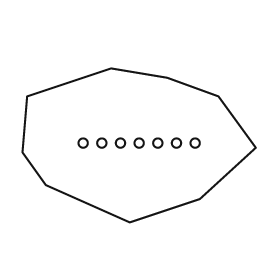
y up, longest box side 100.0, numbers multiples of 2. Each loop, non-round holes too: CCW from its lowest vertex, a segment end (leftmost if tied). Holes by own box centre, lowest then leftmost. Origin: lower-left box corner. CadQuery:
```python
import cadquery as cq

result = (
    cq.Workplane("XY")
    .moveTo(46.0, 0.0)
    .lineTo(76.0, 10.0)
    .lineTo(100.0, 32.0)
    .lineTo(84.0, 54.0)
    .lineTo(62.0, 62.0)
    .lineTo(38.0, 66.0)
    .lineTo(2.0, 54.0)
    .lineTo(0.0, 30.0)
    .lineTo(10.0, 16.0)
    .close()
    .moveTo(26.0, 34.0)
    .circle(2.0)
    .moveTo(34.0, 34.0)
    .circle(2.0)
    .moveTo(42.0, 34.0)
    .circle(2.0)
    .moveTo(50.0, 34.0)
    .circle(2.0)
    .moveTo(58.0, 34.0)
    .circle(2.0)
    .moveTo(66.0, 34.0)
    .circle(2.0)
    .moveTo(74.0, 34.0)
    .circle(2.0)
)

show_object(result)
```